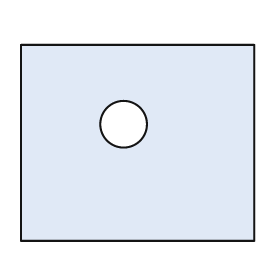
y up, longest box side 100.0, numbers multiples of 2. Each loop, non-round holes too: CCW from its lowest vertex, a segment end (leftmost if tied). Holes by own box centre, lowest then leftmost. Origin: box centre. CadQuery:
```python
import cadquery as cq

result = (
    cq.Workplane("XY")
    .moveTo(-50.0, -42.0)
    .lineTo(50.0, -42.0)
    .lineTo(50.0, 42.0)
    .lineTo(-50.0, 42.0)
    .close()
    .moveTo(-6.0, 8.0)
    .circle(10.0)
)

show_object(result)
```